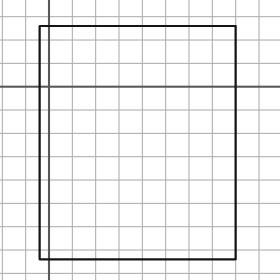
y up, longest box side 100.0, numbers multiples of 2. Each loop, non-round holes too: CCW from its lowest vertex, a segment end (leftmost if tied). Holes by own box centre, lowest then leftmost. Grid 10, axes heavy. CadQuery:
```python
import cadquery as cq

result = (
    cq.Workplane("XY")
    .moveTo(-4.0, -74.0)
    .lineTo(80.0, -74.0)
    .lineTo(80.0, 26.0)
    .lineTo(-4.0, 26.0)
    .close()
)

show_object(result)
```